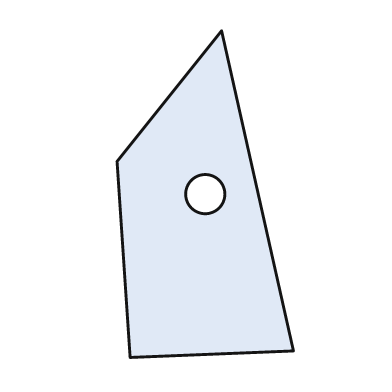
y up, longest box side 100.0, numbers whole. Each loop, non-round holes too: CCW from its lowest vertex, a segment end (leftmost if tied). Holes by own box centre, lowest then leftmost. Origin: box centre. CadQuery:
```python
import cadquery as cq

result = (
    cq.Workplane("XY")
    .moveTo(-23.0, -50.0)
    .lineTo(27.0, -48.0)
    .lineTo(5.0, 50.0)
    .lineTo(-27.0, 10.0)
    .close()
    .moveTo(0.0, 0.0)
    .circle(6.0)
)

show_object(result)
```